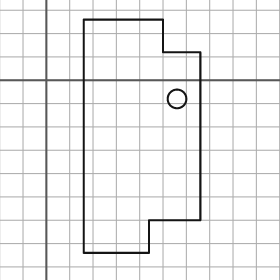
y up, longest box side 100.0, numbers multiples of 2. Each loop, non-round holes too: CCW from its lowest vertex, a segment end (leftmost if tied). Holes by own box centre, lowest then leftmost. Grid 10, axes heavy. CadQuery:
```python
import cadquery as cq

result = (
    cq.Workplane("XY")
    .moveTo(16.0, -74.0)
    .lineTo(44.0, -74.0)
    .lineTo(44.0, -60.0)
    .lineTo(66.0, -60.0)
    .lineTo(66.0, 12.0)
    .lineTo(50.0, 12.0)
    .lineTo(50.0, 26.0)
    .lineTo(16.0, 26.0)
    .close()
    .moveTo(56.0, -8.0)
    .circle(4.0)
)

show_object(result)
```